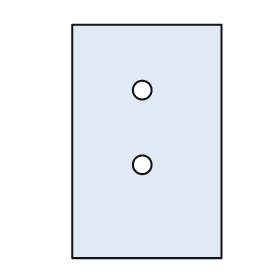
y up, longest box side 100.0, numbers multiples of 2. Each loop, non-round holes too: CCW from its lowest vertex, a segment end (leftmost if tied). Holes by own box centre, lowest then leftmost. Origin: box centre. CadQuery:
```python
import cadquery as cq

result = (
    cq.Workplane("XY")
    .moveTo(-32.0, -50.0)
    .lineTo(32.0, -50.0)
    .lineTo(32.0, 50.0)
    .lineTo(-32.0, 50.0)
    .close()
    .moveTo(-2.0, -10.0)
    .circle(4.0)
    .moveTo(-2.0, 22.0)
    .circle(4.0)
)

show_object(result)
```